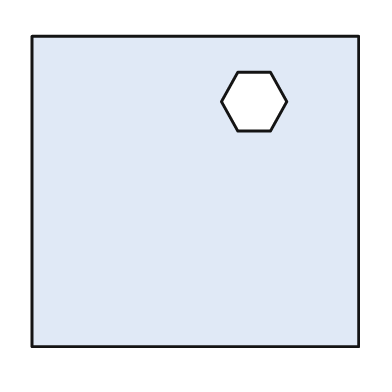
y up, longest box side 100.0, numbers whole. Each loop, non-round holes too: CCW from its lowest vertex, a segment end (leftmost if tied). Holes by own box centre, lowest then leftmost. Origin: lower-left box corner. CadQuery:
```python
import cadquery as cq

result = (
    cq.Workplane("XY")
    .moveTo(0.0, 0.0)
    .lineTo(100.0, 0.0)
    .lineTo(100.0, 95.0)
    .lineTo(0.0, 95.0)
    .close()
    .moveTo(63.0, 66.0)
    .lineTo(73.0, 66.0)
    .lineTo(78.0, 75.0)
    .lineTo(73.0, 84.0)
    .lineTo(63.0, 84.0)
    .lineTo(58.0, 75.0)
    .close()
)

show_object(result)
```